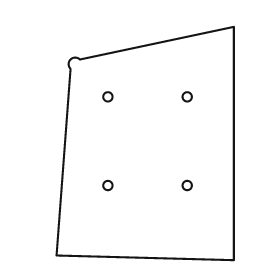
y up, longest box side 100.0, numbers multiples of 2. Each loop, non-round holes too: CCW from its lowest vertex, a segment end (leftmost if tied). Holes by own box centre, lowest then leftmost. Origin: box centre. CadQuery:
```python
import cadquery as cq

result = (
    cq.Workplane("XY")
    .moveTo(38.0, -50.0)
    .lineTo(38.0, 50.0)
    .lineTo(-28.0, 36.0)
    .threePointArc((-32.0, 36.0), (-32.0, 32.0))
    .lineTo(-38.0, -48.0)
    .close()
    .moveTo(-16.0, -18.0)
    .circle(2.0)
    .moveTo(18.0, -18.0)
    .circle(2.0)
    .moveTo(-16.0, 20.0)
    .circle(2.0)
    .moveTo(18.0, 20.0)
    .circle(2.0)
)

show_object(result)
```